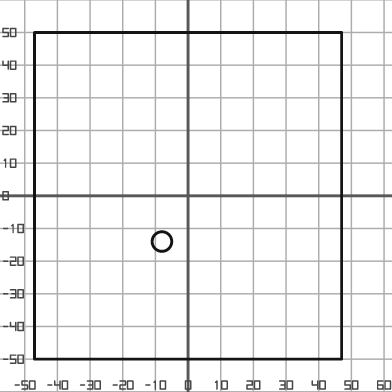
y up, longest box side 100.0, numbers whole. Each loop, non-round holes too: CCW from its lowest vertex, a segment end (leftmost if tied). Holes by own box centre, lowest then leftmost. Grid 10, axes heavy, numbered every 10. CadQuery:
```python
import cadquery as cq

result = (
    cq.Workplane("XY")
    .moveTo(-47.0, -50.0)
    .lineTo(47.0, -50.0)
    .lineTo(47.0, 50.0)
    .lineTo(-47.0, 50.0)
    .close()
    .moveTo(-8.0, -14.0)
    .circle(3.0)
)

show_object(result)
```